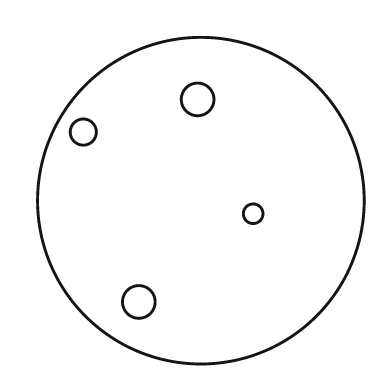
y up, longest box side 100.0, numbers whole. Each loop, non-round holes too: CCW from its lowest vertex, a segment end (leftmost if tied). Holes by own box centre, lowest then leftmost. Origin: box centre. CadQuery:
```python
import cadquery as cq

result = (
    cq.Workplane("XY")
    .moveTo(0.0, 0.0)
    .circle(50.0)
    .moveTo(-19.0, -31.0)
    .circle(5.0)
    .moveTo(16.0, -4.0)
    .circle(3.0)
    .moveTo(-36.0, 21.0)
    .circle(4.0)
    .moveTo(-1.0, 31.0)
    .circle(5.0)
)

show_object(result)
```